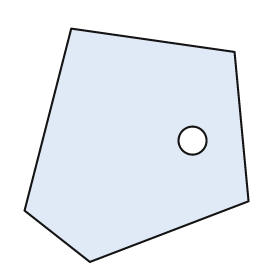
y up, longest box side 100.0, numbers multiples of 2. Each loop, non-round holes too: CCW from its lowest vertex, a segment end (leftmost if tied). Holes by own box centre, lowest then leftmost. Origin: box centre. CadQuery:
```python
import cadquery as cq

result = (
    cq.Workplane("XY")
    .moveTo(-20.0, -50.0)
    .lineTo(48.0, -24.0)
    .lineTo(42.0, 40.0)
    .lineTo(-28.0, 50.0)
    .lineTo(-48.0, -28.0)
    .close()
    .moveTo(24.0, 2.0)
    .circle(6.0)
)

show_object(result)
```